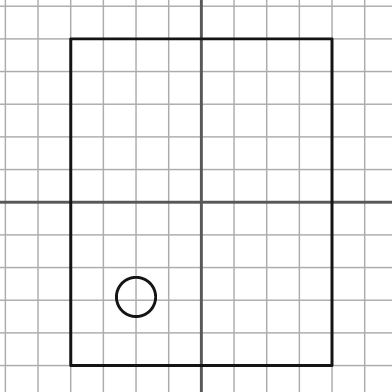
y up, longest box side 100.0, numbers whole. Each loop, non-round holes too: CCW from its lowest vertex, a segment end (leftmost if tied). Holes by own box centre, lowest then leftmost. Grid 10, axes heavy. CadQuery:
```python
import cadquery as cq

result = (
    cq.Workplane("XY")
    .moveTo(-40.0, -50.0)
    .lineTo(40.0, -50.0)
    .lineTo(40.0, 50.0)
    .lineTo(-40.0, 50.0)
    .close()
    .moveTo(-20.0, -29.0)
    .circle(6.0)
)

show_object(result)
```